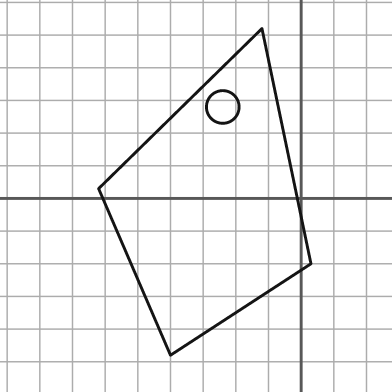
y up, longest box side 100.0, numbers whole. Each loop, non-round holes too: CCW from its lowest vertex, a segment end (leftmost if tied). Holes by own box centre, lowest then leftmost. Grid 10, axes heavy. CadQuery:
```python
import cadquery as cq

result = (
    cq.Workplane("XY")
    .moveTo(-40.0, -48.0)
    .lineTo(3.0, -20.0)
    .lineTo(-12.0, 52.0)
    .lineTo(-62.0, 3.0)
    .close()
    .moveTo(-24.0, 28.0)
    .circle(5.0)
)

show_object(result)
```